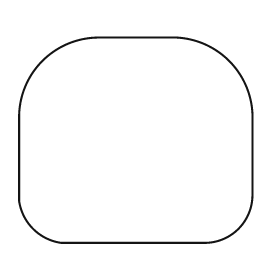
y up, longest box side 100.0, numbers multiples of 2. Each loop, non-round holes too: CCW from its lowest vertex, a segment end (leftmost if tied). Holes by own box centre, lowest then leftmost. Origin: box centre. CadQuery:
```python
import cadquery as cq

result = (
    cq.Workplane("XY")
    .moveTo(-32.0, -44.0)
    .lineTo(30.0, -44.0)
    .threePointArc((44.0, -38.0), (50.0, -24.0))
    .lineTo(50.0, 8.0)
    .threePointArc((40.0, 34.0), (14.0, 44.0))
    .lineTo(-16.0, 44.0)
    .threePointArc((-40.0, 34.0), (-50.0, 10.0))
    .lineTo(-50.0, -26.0)
    .threePointArc((-44.0, -38.0), (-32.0, -44.0))
    .close()
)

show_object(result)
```